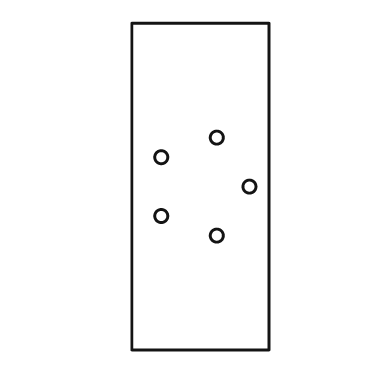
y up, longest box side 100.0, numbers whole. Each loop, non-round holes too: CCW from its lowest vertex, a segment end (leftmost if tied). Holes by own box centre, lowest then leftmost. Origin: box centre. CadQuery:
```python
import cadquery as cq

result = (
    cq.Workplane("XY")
    .moveTo(-21.0, -50.0)
    .lineTo(21.0, -50.0)
    .lineTo(21.0, 50.0)
    .lineTo(-21.0, 50.0)
    .close()
    .moveTo(5.0, -15.0)
    .circle(2.0)
    .moveTo(-12.0, -9.0)
    .circle(2.0)
    .moveTo(15.0, 0.0)
    .circle(2.0)
    .moveTo(-12.0, 9.0)
    .circle(2.0)
    .moveTo(5.0, 15.0)
    .circle(2.0)
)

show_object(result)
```